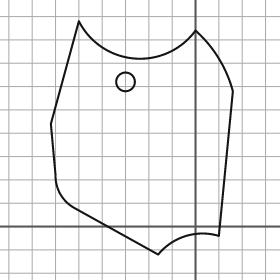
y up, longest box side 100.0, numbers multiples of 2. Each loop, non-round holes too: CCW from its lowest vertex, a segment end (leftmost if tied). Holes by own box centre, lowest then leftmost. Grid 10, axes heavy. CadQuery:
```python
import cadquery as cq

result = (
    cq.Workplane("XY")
    .moveTo(-16.0, -12.0)
    .threePointArc((-4.0, -4.0), (10.0, -4.0))
    .lineTo(16.0, 58.0)
    .threePointArc((10.0, 72.0), (0.0, 84.0))
    .threePointArc((-26.0, 72.0), (-50.0, 88.0))
    .lineTo(-62.0, 44.0)
    .lineTo(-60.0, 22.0)
    .threePointArc((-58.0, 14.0), (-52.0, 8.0))
    .close()
    .moveTo(-30.0, 62.0)
    .circle(4.0)
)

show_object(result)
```